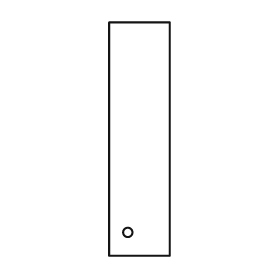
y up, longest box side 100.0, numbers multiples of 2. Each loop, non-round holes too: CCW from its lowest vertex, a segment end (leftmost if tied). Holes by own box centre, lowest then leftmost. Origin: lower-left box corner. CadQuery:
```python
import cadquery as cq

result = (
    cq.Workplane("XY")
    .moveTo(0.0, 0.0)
    .lineTo(26.0, 0.0)
    .lineTo(26.0, 100.0)
    .lineTo(0.0, 100.0)
    .close()
    .moveTo(8.0, 10.0)
    .circle(2.0)
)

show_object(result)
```